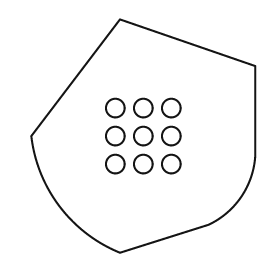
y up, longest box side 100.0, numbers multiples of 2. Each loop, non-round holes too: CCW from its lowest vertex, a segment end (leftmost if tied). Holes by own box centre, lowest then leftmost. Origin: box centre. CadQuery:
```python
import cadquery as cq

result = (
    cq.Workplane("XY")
    .moveTo(-10.0, -50.0)
    .lineTo(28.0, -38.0)
    .threePointArc((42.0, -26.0), (48.0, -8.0))
    .lineTo(48.0, 30.0)
    .lineTo(-10.0, 50.0)
    .lineTo(-48.0, 0.0)
    .threePointArc((-36.0, -30.0), (-10.0, -50.0))
    .close()
    .moveTo(-12.0, -12.0)
    .circle(4.0)
    .moveTo(0.0, -12.0)
    .circle(4.0)
    .moveTo(12.0, -12.0)
    .circle(4.0)
    .moveTo(-12.0, 0.0)
    .circle(4.0)
    .moveTo(0.0, 0.0)
    .circle(4.0)
    .moveTo(12.0, 0.0)
    .circle(4.0)
    .moveTo(-12.0, 12.0)
    .circle(4.0)
    .moveTo(0.0, 12.0)
    .circle(4.0)
    .moveTo(12.0, 12.0)
    .circle(4.0)
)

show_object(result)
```